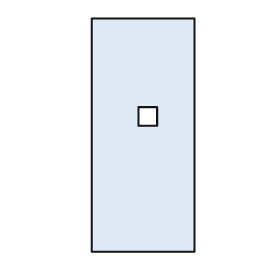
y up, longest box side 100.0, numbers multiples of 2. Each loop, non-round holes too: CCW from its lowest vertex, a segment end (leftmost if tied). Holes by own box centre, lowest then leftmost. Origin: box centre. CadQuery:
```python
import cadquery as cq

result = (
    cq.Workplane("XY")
    .moveTo(-22.0, -50.0)
    .lineTo(22.0, -50.0)
    .lineTo(22.0, 50.0)
    .lineTo(-22.0, 50.0)
    .close()
    .moveTo(-2.0, 4.0)
    .lineTo(6.0, 4.0)
    .lineTo(6.0, 12.0)
    .lineTo(-2.0, 12.0)
    .close()
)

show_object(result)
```